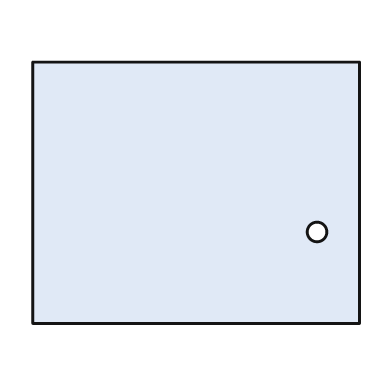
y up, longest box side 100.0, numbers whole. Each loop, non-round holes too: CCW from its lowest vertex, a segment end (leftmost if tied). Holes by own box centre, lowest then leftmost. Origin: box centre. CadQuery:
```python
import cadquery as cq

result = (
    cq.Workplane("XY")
    .moveTo(-50.0, -40.0)
    .lineTo(50.0, -40.0)
    .lineTo(50.0, 40.0)
    .lineTo(-50.0, 40.0)
    .close()
    .moveTo(37.0, -12.0)
    .circle(3.0)
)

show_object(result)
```